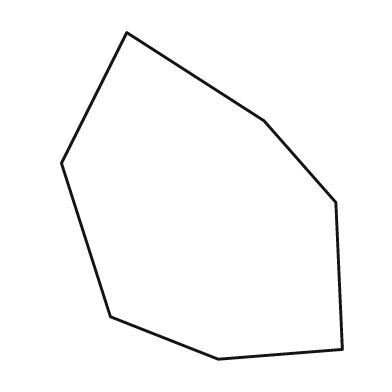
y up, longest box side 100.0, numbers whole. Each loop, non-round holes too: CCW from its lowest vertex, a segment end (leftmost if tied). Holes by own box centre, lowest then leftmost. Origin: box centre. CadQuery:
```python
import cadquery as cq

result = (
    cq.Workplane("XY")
    .moveTo(5.0, -50.0)
    .lineTo(43.0, -47.0)
    .lineTo(41.0, -2.0)
    .lineTo(19.0, 23.0)
    .lineTo(-23.0, 50.0)
    .lineTo(-43.0, 10.0)
    .lineTo(-28.0, -37.0)
    .close()
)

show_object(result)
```